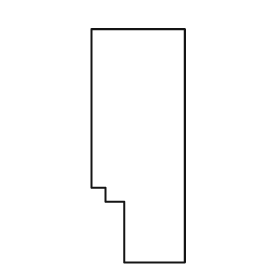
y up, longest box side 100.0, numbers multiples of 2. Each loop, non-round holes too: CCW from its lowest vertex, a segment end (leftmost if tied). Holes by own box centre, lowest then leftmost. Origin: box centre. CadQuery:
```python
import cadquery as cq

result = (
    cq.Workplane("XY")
    .moveTo(-6.0, -50.0)
    .lineTo(20.0, -50.0)
    .lineTo(20.0, 50.0)
    .lineTo(-20.0, 50.0)
    .lineTo(-20.0, -18.0)
    .lineTo(-14.0, -18.0)
    .lineTo(-14.0, -24.0)
    .lineTo(-6.0, -24.0)
    .close()
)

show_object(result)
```